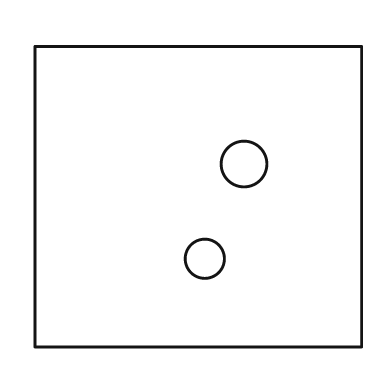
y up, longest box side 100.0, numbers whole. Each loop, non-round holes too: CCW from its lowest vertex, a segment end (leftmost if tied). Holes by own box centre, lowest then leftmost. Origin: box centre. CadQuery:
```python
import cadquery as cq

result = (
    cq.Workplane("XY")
    .moveTo(-50.0, -46.0)
    .lineTo(50.0, -46.0)
    .lineTo(50.0, 46.0)
    .lineTo(-50.0, 46.0)
    .close()
    .moveTo(2.0, -19.0)
    .circle(6.0)
    .moveTo(14.0, 10.0)
    .circle(7.0)
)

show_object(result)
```